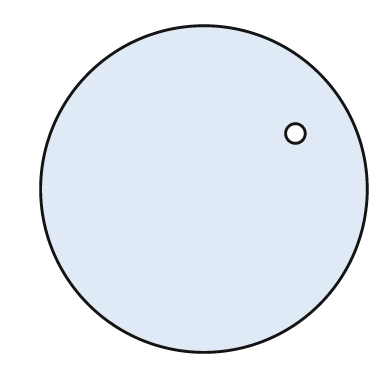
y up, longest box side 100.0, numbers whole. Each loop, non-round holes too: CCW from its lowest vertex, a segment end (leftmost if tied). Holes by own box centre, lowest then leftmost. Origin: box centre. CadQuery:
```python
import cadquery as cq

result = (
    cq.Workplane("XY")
    .moveTo(0.0, 0.0)
    .circle(50.0)
    .moveTo(28.0, 17.0)
    .circle(3.0)
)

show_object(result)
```